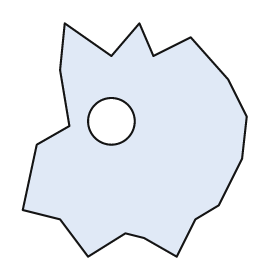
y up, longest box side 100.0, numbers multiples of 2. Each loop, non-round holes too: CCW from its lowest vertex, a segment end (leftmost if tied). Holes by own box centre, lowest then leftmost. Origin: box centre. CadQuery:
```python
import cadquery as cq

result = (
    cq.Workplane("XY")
    .moveTo(-20.0, -50.0)
    .lineTo(-4.0, -40.0)
    .lineTo(4.0, -42.0)
    .lineTo(18.0, -50.0)
    .lineTo(26.0, -34.0)
    .lineTo(36.0, -28.0)
    .lineTo(46.0, -8.0)
    .lineTo(48.0, 10.0)
    .lineTo(40.0, 26.0)
    .lineTo(24.0, 44.0)
    .lineTo(8.0, 36.0)
    .lineTo(2.0, 50.0)
    .lineTo(-10.0, 36.0)
    .lineTo(-30.0, 50.0)
    .lineTo(-32.0, 30.0)
    .lineTo(-28.0, 6.0)
    .lineTo(-42.0, -2.0)
    .lineTo(-48.0, -30.0)
    .lineTo(-32.0, -34.0)
    .close()
    .moveTo(-10.0, 8.0)
    .circle(10.0)
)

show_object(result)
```